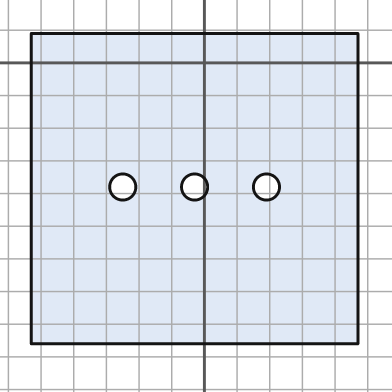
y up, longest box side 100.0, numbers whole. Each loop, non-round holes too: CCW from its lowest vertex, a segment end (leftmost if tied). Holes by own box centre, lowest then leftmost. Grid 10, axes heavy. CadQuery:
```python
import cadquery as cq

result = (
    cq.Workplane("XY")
    .moveTo(-53.0, -86.0)
    .lineTo(47.0, -86.0)
    .lineTo(47.0, 9.0)
    .lineTo(-53.0, 9.0)
    .close()
    .moveTo(-25.0, -38.0)
    .circle(4.0)
    .moveTo(-3.0, -38.0)
    .circle(4.0)
    .moveTo(19.0, -38.0)
    .circle(4.0)
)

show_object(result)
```